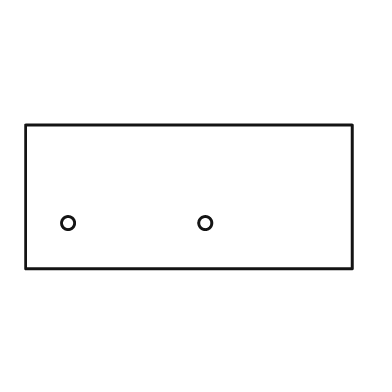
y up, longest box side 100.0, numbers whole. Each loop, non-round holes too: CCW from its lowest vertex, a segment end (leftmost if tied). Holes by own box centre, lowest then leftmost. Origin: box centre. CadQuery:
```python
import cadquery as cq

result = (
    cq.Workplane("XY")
    .moveTo(-50.0, -22.0)
    .lineTo(50.0, -22.0)
    .lineTo(50.0, 22.0)
    .lineTo(-50.0, 22.0)
    .close()
    .moveTo(-37.0, -8.0)
    .circle(2.0)
    .moveTo(5.0, -8.0)
    .circle(2.0)
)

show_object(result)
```